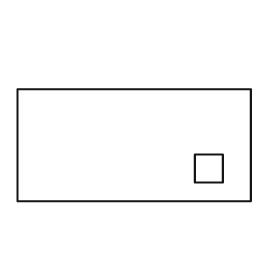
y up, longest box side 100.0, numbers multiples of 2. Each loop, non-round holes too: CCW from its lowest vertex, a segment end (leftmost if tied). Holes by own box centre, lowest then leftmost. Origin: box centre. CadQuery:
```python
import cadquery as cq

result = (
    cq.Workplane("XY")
    .moveTo(-50.0, -24.0)
    .lineTo(50.0, -24.0)
    .lineTo(50.0, 24.0)
    .lineTo(-50.0, 24.0)
    .close()
    .moveTo(26.0, -16.0)
    .lineTo(38.0, -16.0)
    .lineTo(38.0, -4.0)
    .lineTo(26.0, -4.0)
    .close()
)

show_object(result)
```